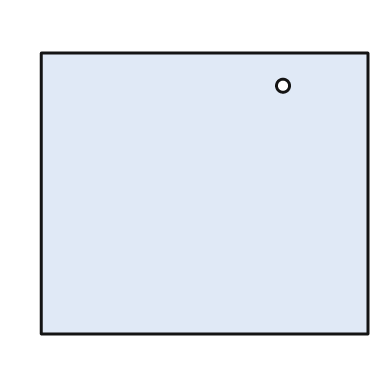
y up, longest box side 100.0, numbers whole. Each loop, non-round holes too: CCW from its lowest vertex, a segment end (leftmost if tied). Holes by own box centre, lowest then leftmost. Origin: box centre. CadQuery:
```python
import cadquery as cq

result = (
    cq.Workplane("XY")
    .moveTo(-50.0, -43.0)
    .lineTo(50.0, -43.0)
    .lineTo(50.0, 43.0)
    .lineTo(-50.0, 43.0)
    .close()
    .moveTo(24.0, 33.0)
    .circle(2.0)
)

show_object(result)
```